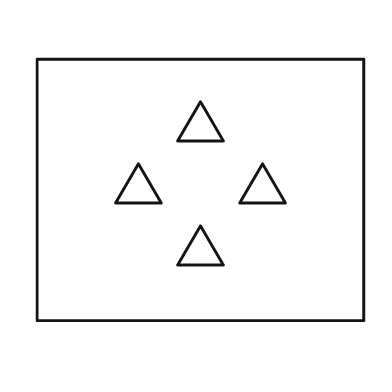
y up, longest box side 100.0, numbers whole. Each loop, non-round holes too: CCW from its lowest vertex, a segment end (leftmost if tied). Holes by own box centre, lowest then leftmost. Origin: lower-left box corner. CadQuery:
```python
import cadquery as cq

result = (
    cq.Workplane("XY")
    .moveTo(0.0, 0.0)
    .lineTo(100.0, 0.0)
    .lineTo(100.0, 80.0)
    .lineTo(0.0, 80.0)
    .close()
    .moveTo(43.0, 17.0)
    .lineTo(57.0, 17.0)
    .lineTo(50.0, 29.0)
    .close()
    .moveTo(24.0, 36.0)
    .lineTo(38.0, 36.0)
    .lineTo(31.0, 48.0)
    .close()
    .moveTo(62.0, 36.0)
    .lineTo(76.0, 36.0)
    .lineTo(69.0, 48.0)
    .close()
    .moveTo(43.0, 55.0)
    .lineTo(57.0, 55.0)
    .lineTo(50.0, 67.0)
    .close()
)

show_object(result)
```